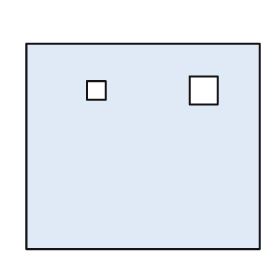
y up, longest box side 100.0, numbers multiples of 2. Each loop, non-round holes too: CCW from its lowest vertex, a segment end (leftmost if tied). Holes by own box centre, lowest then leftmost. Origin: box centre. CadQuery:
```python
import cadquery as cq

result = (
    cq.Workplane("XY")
    .moveTo(-50.0, -44.0)
    .lineTo(50.0, -44.0)
    .lineTo(50.0, 44.0)
    .lineTo(-50.0, 44.0)
    .close()
    .moveTo(-24.0, 20.0)
    .lineTo(-16.0, 20.0)
    .lineTo(-16.0, 28.0)
    .lineTo(-24.0, 28.0)
    .close()
    .moveTo(20.0, 18.0)
    .lineTo(32.0, 18.0)
    .lineTo(32.0, 30.0)
    .lineTo(20.0, 30.0)
    .close()
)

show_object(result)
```